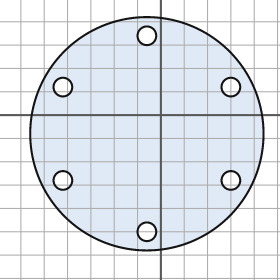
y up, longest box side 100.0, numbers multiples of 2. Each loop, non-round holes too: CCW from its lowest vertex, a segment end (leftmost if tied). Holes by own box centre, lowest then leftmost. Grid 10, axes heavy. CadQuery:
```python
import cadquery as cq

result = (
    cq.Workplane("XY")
    .moveTo(-6.0, -8.0)
    .circle(50.0)
    .moveTo(-6.0, -50.0)
    .circle(4.0)
    .moveTo(-42.0, -28.0)
    .circle(4.0)
    .moveTo(30.0, -28.0)
    .circle(4.0)
    .moveTo(-42.0, 12.0)
    .circle(4.0)
    .moveTo(30.0, 12.0)
    .circle(4.0)
    .moveTo(-6.0, 34.0)
    .circle(4.0)
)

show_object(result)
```